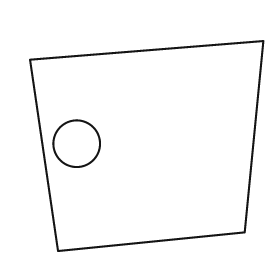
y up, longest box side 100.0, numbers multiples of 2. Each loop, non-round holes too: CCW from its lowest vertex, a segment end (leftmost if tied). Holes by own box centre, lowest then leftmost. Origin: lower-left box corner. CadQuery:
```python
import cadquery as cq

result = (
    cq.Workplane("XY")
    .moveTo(12.0, 0.0)
    .lineTo(92.0, 8.0)
    .lineTo(100.0, 90.0)
    .lineTo(0.0, 82.0)
    .close()
    .moveTo(20.0, 46.0)
    .circle(10.0)
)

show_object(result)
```